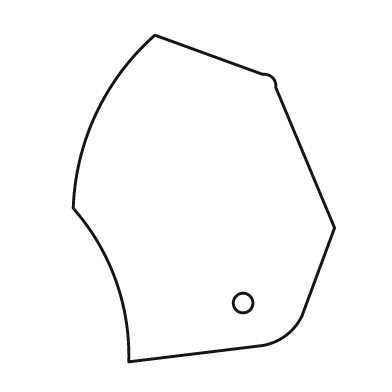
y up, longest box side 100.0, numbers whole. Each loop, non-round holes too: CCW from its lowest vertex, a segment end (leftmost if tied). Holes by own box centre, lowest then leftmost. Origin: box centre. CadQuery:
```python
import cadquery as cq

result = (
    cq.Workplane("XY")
    .moveTo(-23.0, -50.0)
    .lineTo(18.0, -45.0)
    .threePointArc((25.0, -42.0), (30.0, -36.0))
    .lineTo(40.0, -9.0)
    .lineTo(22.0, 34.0)
    .threePointArc((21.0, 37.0), (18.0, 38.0))
    .lineTo(-15.0, 50.0)
    .threePointArc((-33.0, 26.0), (-40.0, -3.0))
    .threePointArc((-27.0, -25.0), (-23.0, -50.0))
    .close()
    .moveTo(12.0, -32.0)
    .circle(3.0)
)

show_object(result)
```